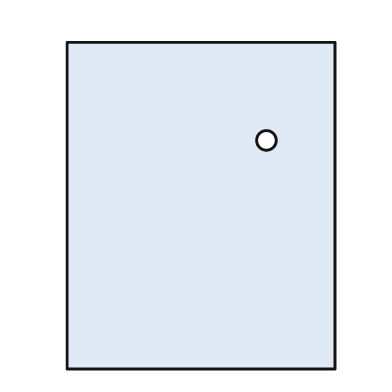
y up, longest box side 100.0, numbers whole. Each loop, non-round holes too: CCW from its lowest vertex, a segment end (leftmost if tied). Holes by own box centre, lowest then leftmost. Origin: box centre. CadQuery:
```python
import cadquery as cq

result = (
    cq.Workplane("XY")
    .moveTo(-41.0, -50.0)
    .lineTo(41.0, -50.0)
    .lineTo(41.0, 50.0)
    .lineTo(-41.0, 50.0)
    .close()
    .moveTo(20.0, 20.0)
    .circle(3.0)
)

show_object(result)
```